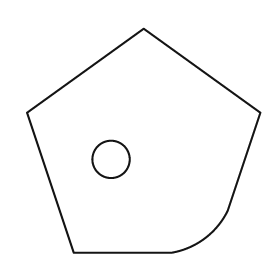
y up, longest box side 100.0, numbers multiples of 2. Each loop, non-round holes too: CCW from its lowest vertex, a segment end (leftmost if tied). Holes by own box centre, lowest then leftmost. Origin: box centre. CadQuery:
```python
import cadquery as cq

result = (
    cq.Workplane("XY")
    .moveTo(-30.0, -48.0)
    .lineTo(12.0, -48.0)
    .threePointArc((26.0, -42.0), (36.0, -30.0))
    .lineTo(50.0, 12.0)
    .lineTo(0.0, 48.0)
    .lineTo(-50.0, 12.0)
    .close()
    .moveTo(-14.0, -8.0)
    .circle(8.0)
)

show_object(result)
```